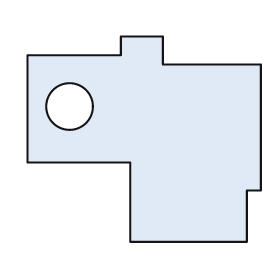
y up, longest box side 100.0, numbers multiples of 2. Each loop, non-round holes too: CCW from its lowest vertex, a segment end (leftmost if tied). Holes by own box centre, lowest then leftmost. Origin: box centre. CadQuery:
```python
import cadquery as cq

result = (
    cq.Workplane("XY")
    .moveTo(-6.0, -44.0)
    .lineTo(44.0, -44.0)
    .lineTo(44.0, -22.0)
    .lineTo(50.0, -22.0)
    .lineTo(50.0, 32.0)
    .lineTo(8.0, 32.0)
    .lineTo(8.0, 44.0)
    .lineTo(-10.0, 44.0)
    .lineTo(-10.0, 36.0)
    .lineTo(-50.0, 36.0)
    .lineTo(-50.0, -10.0)
    .lineTo(-6.0, -10.0)
    .close()
    .moveTo(-32.0, 14.0)
    .circle(10.0)
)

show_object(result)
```